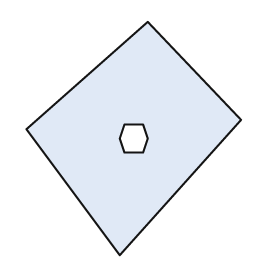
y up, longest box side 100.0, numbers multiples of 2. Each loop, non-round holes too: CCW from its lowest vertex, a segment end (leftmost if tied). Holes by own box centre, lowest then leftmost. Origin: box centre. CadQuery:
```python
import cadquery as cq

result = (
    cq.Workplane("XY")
    .moveTo(-6.0, -50.0)
    .lineTo(46.0, 8.0)
    .lineTo(6.0, 50.0)
    .lineTo(-46.0, 4.0)
    .close()
    .moveTo(-4.0, -6.0)
    .lineTo(4.0, -6.0)
    .lineTo(6.0, 0.0)
    .lineTo(4.0, 6.0)
    .lineTo(-4.0, 6.0)
    .lineTo(-6.0, 0.0)
    .close()
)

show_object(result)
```